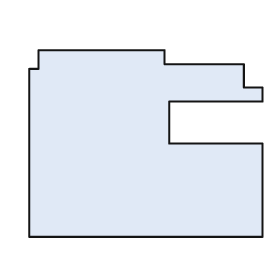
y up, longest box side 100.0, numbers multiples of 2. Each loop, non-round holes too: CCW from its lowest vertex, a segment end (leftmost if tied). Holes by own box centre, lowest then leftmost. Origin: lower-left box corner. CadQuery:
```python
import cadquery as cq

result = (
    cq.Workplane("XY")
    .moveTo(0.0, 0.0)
    .lineTo(100.0, 0.0)
    .lineTo(100.0, 40.0)
    .lineTo(60.0, 40.0)
    .lineTo(60.0, 58.0)
    .lineTo(100.0, 58.0)
    .lineTo(100.0, 64.0)
    .lineTo(92.0, 64.0)
    .lineTo(92.0, 74.0)
    .lineTo(58.0, 74.0)
    .lineTo(58.0, 80.0)
    .lineTo(4.0, 80.0)
    .lineTo(4.0, 72.0)
    .lineTo(0.0, 72.0)
    .close()
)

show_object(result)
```